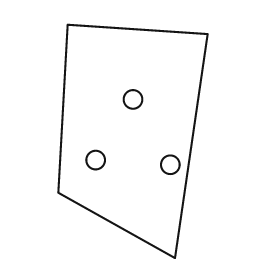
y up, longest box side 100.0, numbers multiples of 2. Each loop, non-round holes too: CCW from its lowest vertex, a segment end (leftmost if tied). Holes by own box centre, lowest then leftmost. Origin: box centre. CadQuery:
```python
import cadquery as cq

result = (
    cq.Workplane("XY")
    .moveTo(18.0, -50.0)
    .lineTo(32.0, 46.0)
    .lineTo(-28.0, 50.0)
    .lineTo(-32.0, -22.0)
    .close()
    .moveTo(16.0, -10.0)
    .circle(4.0)
    .moveTo(-16.0, -8.0)
    .circle(4.0)
    .moveTo(0.0, 18.0)
    .circle(4.0)
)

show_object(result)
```